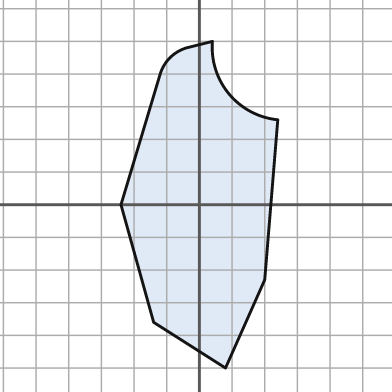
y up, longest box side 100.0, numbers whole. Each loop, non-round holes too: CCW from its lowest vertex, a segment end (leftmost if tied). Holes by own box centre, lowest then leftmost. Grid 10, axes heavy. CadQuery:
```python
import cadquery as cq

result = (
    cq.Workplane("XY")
    .moveTo(8.0, -50.0)
    .lineTo(20.0, -23.0)
    .lineTo(24.0, 26.0)
    .threePointArc((9.0, 34.0), (4.0, 50.0))
    .lineTo(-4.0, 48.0)
    .threePointArc((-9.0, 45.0), (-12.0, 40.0))
    .lineTo(-24.0, 0.0)
    .lineTo(-14.0, -36.0)
    .close()
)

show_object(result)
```